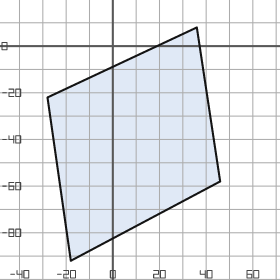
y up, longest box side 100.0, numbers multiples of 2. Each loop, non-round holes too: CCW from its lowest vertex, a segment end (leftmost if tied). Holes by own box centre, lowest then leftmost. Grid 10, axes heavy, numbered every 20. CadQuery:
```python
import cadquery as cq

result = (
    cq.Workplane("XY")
    .moveTo(-18.0, -92.0)
    .lineTo(46.0, -58.0)
    .lineTo(36.0, 8.0)
    .lineTo(-28.0, -22.0)
    .close()
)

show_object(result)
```